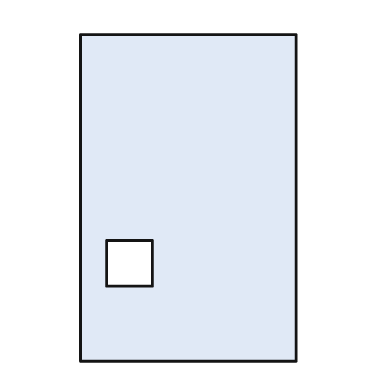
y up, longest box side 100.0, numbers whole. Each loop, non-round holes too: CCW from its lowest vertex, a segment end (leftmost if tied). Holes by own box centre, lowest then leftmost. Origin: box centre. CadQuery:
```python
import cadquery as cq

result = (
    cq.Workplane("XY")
    .moveTo(-33.0, -50.0)
    .lineTo(33.0, -50.0)
    .lineTo(33.0, 50.0)
    .lineTo(-33.0, 50.0)
    .close()
    .moveTo(-25.0, -27.0)
    .lineTo(-11.0, -27.0)
    .lineTo(-11.0, -13.0)
    .lineTo(-25.0, -13.0)
    .close()
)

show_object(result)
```